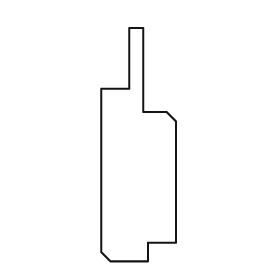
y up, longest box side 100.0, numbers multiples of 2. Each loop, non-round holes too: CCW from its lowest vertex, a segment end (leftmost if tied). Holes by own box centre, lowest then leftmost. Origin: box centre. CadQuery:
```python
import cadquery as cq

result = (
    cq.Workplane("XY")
    .moveTo(-12.0, -50.0)
    .lineTo(4.0, -50.0)
    .lineTo(4.0, -42.0)
    .lineTo(16.0, -42.0)
    .lineTo(16.0, 10.0)
    .lineTo(12.0, 14.0)
    .lineTo(2.0, 14.0)
    .lineTo(2.0, 50.0)
    .lineTo(-4.0, 50.0)
    .lineTo(-4.0, 24.0)
    .lineTo(-16.0, 24.0)
    .lineTo(-16.0, -46.0)
    .close()
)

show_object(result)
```